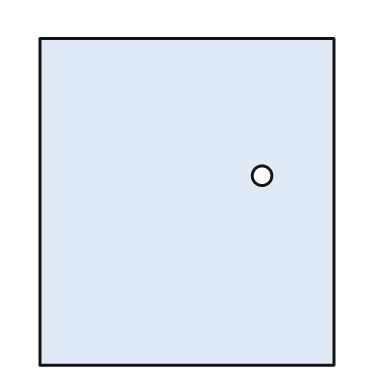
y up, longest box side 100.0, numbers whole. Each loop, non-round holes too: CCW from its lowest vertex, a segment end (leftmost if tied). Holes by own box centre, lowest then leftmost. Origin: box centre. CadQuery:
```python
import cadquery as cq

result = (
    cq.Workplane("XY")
    .moveTo(-45.0, -50.0)
    .lineTo(45.0, -50.0)
    .lineTo(45.0, 50.0)
    .lineTo(-45.0, 50.0)
    .close()
    .moveTo(23.0, 8.0)
    .circle(3.0)
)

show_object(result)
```